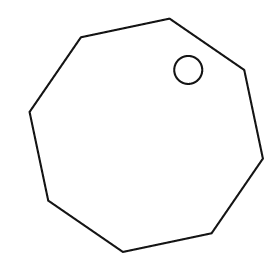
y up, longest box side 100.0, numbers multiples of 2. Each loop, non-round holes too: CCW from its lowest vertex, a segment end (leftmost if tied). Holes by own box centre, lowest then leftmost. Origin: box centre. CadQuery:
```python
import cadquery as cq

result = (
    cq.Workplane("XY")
    .moveTo(-10.0, -50.0)
    .lineTo(28.0, -42.0)
    .lineTo(50.0, -10.0)
    .lineTo(42.0, 28.0)
    .lineTo(10.0, 50.0)
    .lineTo(-28.0, 42.0)
    .lineTo(-50.0, 10.0)
    .lineTo(-42.0, -28.0)
    .close()
    .moveTo(18.0, 28.0)
    .circle(6.0)
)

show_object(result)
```